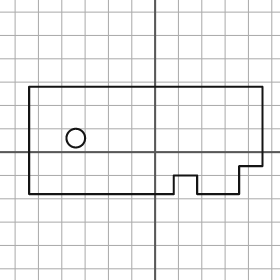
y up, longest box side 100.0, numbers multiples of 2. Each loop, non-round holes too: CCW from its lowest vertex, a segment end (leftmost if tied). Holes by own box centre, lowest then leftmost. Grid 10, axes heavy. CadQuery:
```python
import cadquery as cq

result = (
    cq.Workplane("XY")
    .moveTo(-54.0, -18.0)
    .lineTo(8.0, -18.0)
    .lineTo(8.0, -10.0)
    .lineTo(18.0, -10.0)
    .lineTo(18.0, -18.0)
    .lineTo(36.0, -18.0)
    .lineTo(36.0, -6.0)
    .lineTo(46.0, -6.0)
    .lineTo(46.0, 28.0)
    .lineTo(-54.0, 28.0)
    .close()
    .moveTo(-34.0, 6.0)
    .circle(4.0)
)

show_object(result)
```